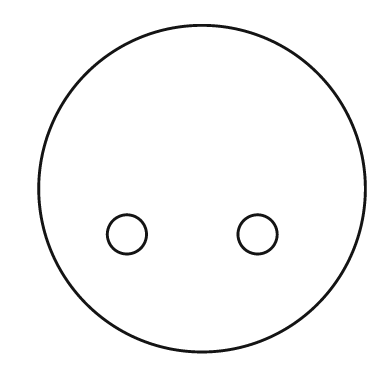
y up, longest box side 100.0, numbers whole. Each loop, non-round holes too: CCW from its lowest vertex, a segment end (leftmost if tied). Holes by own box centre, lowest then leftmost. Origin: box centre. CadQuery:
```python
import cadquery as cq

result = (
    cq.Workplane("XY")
    .moveTo(0.0, 0.0)
    .circle(50.0)
    .moveTo(-23.0, -14.0)
    .circle(6.0)
    .moveTo(17.0, -14.0)
    .circle(6.0)
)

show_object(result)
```